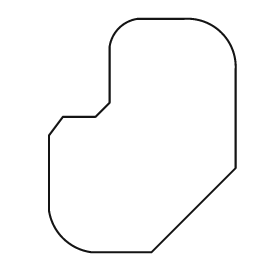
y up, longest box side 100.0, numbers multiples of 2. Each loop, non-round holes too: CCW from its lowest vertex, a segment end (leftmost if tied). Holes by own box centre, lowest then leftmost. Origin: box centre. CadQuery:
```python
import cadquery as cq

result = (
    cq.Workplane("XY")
    .moveTo(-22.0, -50.0)
    .lineTo(4.0, -50.0)
    .lineTo(40.0, -14.0)
    .lineTo(40.0, 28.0)
    .threePointArc((34.0, 44.0), (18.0, 50.0))
    .lineTo(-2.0, 50.0)
    .threePointArc((-10.0, 46.0), (-14.0, 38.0))
    .lineTo(-14.0, 14.0)
    .lineTo(-20.0, 8.0)
    .lineTo(-34.0, 8.0)
    .lineTo(-40.0, 0.0)
    .lineTo(-40.0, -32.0)
    .threePointArc((-34.0, -44.0), (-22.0, -50.0))
    .close()
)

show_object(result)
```